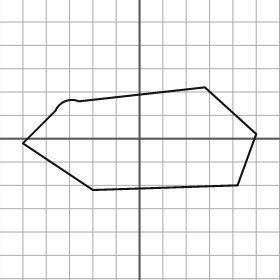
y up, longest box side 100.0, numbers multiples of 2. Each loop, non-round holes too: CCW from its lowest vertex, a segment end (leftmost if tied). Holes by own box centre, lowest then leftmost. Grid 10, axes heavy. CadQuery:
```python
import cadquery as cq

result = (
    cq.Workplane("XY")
    .moveTo(-20.0, -22.0)
    .lineTo(42.0, -20.0)
    .lineTo(50.0, 2.0)
    .lineTo(28.0, 22.0)
    .lineTo(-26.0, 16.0)
    .threePointArc((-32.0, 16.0), (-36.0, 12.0))
    .lineTo(-50.0, -2.0)
    .close()
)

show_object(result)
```